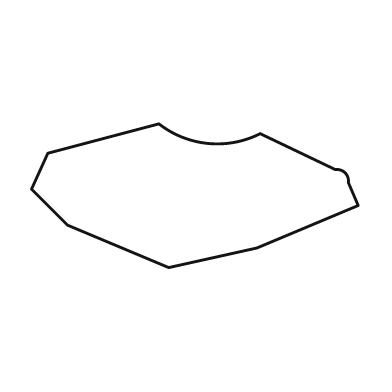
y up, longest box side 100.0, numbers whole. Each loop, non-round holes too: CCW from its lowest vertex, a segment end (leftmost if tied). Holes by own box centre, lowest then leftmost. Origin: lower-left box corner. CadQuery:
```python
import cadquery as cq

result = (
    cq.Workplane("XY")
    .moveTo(42.0, 0.0)
    .lineTo(69.0, 6.0)
    .lineTo(100.0, 19.0)
    .lineTo(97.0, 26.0)
    .threePointArc((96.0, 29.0), (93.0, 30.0))
    .lineTo(70.0, 41.0)
    .threePointArc((54.0, 38.0), (39.0, 44.0))
    .lineTo(5.0, 35.0)
    .lineTo(0.0, 24.0)
    .lineTo(11.0, 13.0)
    .close()
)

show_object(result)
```